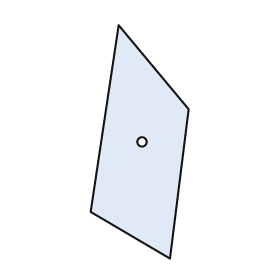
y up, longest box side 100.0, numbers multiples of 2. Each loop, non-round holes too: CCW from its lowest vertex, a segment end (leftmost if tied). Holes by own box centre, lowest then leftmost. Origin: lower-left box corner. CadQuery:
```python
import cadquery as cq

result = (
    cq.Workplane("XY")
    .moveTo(34.0, 0.0)
    .lineTo(42.0, 64.0)
    .lineTo(12.0, 100.0)
    .lineTo(0.0, 20.0)
    .close()
    .moveTo(22.0, 50.0)
    .circle(2.0)
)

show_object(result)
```